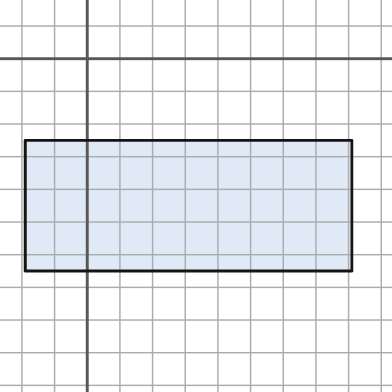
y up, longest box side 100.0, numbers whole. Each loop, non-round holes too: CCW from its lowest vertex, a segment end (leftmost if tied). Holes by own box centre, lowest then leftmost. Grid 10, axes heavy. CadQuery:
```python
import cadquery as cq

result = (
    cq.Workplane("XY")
    .moveTo(-19.0, -65.0)
    .lineTo(81.0, -65.0)
    .lineTo(81.0, -25.0)
    .lineTo(-19.0, -25.0)
    .close()
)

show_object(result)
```